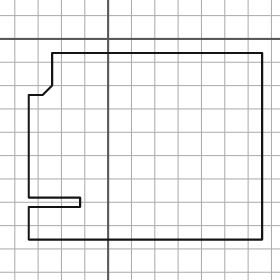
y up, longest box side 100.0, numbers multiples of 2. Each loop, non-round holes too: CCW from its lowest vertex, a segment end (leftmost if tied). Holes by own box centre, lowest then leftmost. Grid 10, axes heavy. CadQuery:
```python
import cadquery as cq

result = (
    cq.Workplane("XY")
    .moveTo(-34.0, -86.0)
    .lineTo(66.0, -86.0)
    .lineTo(66.0, -6.0)
    .lineTo(-24.0, -6.0)
    .lineTo(-24.0, -20.0)
    .lineTo(-28.0, -24.0)
    .lineTo(-34.0, -24.0)
    .lineTo(-34.0, -68.0)
    .lineTo(-12.0, -68.0)
    .lineTo(-12.0, -72.0)
    .lineTo(-34.0, -72.0)
    .close()
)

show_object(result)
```